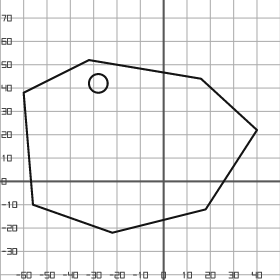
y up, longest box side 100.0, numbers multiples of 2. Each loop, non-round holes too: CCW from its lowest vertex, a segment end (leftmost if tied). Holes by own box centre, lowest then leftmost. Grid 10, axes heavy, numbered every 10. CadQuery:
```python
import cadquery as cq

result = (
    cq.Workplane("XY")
    .moveTo(-22.0, -22.0)
    .lineTo(18.0, -12.0)
    .lineTo(40.0, 22.0)
    .lineTo(16.0, 44.0)
    .lineTo(-32.0, 52.0)
    .lineTo(-60.0, 38.0)
    .lineTo(-56.0, -10.0)
    .close()
    .moveTo(-28.0, 42.0)
    .circle(4.0)
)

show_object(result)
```